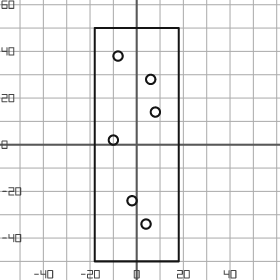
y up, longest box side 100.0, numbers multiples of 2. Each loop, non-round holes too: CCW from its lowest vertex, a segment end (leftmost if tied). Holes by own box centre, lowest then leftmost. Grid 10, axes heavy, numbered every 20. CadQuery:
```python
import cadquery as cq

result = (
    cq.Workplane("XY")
    .moveTo(-18.0, -50.0)
    .lineTo(18.0, -50.0)
    .lineTo(18.0, 50.0)
    .lineTo(-18.0, 50.0)
    .close()
    .moveTo(4.0, -34.0)
    .circle(2.0)
    .moveTo(-2.0, -24.0)
    .circle(2.0)
    .moveTo(-10.0, 2.0)
    .circle(2.0)
    .moveTo(8.0, 14.0)
    .circle(2.0)
    .moveTo(6.0, 28.0)
    .circle(2.0)
    .moveTo(-8.0, 38.0)
    .circle(2.0)
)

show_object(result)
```